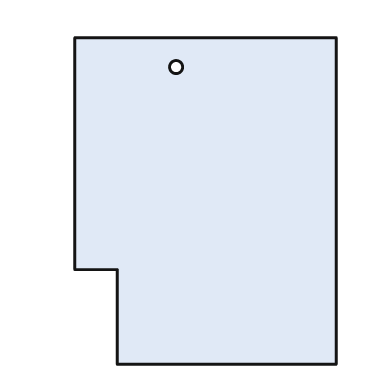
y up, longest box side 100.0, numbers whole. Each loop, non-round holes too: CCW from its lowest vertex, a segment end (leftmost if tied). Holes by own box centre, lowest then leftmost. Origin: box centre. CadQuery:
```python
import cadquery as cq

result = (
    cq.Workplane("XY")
    .moveTo(-27.0, -50.0)
    .lineTo(40.0, -50.0)
    .lineTo(40.0, 50.0)
    .lineTo(-40.0, 50.0)
    .lineTo(-40.0, -21.0)
    .lineTo(-27.0, -21.0)
    .close()
    .moveTo(-9.0, 41.0)
    .circle(2.0)
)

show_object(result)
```